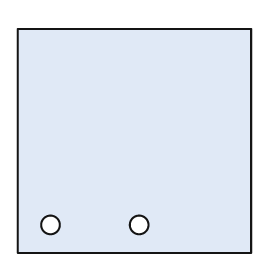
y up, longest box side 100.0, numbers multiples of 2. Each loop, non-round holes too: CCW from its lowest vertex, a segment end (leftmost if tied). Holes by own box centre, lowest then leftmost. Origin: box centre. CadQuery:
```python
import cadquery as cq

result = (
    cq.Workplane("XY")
    .moveTo(-50.0, -48.0)
    .lineTo(50.0, -48.0)
    .lineTo(50.0, 48.0)
    .lineTo(-50.0, 48.0)
    .close()
    .moveTo(-36.0, -36.0)
    .circle(4.0)
    .moveTo(2.0, -36.0)
    .circle(4.0)
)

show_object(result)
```